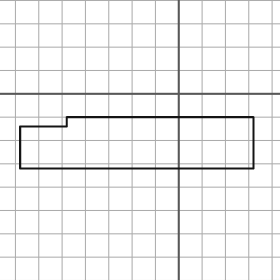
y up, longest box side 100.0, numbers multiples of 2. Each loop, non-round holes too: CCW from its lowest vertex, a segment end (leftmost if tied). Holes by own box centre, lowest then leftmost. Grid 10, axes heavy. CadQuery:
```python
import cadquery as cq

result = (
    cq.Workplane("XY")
    .moveTo(-68.0, -32.0)
    .lineTo(32.0, -32.0)
    .lineTo(32.0, -10.0)
    .lineTo(-48.0, -10.0)
    .lineTo(-48.0, -14.0)
    .lineTo(-68.0, -14.0)
    .close()
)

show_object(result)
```